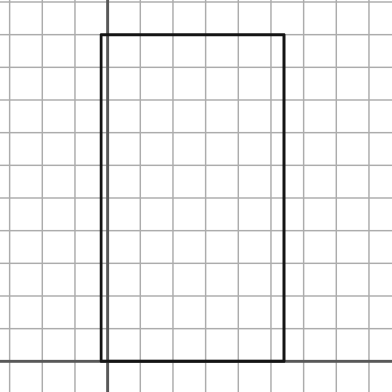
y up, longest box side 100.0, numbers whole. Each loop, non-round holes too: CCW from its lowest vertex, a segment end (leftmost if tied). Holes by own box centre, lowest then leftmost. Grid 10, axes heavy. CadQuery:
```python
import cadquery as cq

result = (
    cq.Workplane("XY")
    .moveTo(-2.0, 0.0)
    .lineTo(54.0, 0.0)
    .lineTo(54.0, 100.0)
    .lineTo(-2.0, 100.0)
    .close()
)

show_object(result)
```